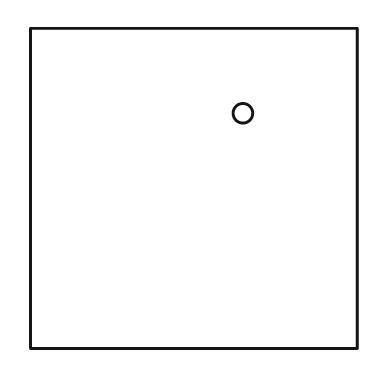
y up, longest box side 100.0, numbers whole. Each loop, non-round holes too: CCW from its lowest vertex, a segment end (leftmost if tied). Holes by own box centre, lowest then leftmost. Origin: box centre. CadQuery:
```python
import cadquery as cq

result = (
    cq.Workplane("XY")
    .moveTo(-50.0, -49.0)
    .lineTo(50.0, -49.0)
    .lineTo(50.0, 49.0)
    .lineTo(-50.0, 49.0)
    .close()
    .moveTo(15.0, 23.0)
    .circle(3.0)
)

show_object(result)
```